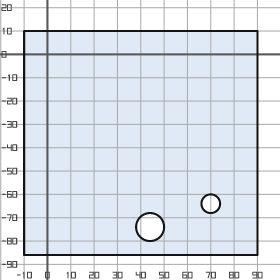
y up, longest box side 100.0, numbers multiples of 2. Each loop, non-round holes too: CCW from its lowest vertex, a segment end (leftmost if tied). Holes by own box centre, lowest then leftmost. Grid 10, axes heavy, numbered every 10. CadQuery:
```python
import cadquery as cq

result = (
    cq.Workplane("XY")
    .moveTo(-10.0, -86.0)
    .lineTo(90.0, -86.0)
    .lineTo(90.0, 10.0)
    .lineTo(-10.0, 10.0)
    .close()
    .moveTo(44.0, -74.0)
    .circle(6.0)
    .moveTo(70.0, -64.0)
    .circle(4.0)
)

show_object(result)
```